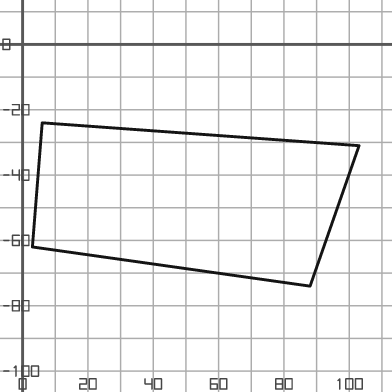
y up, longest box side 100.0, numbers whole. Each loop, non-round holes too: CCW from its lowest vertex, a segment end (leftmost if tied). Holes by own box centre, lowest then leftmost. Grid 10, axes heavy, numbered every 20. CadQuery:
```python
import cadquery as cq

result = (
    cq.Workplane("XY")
    .moveTo(88.0, -74.0)
    .lineTo(103.0, -31.0)
    .lineTo(6.0, -24.0)
    .lineTo(3.0, -62.0)
    .close()
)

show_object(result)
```